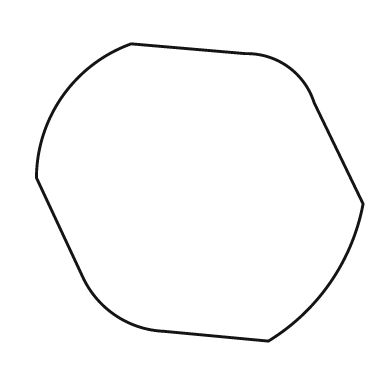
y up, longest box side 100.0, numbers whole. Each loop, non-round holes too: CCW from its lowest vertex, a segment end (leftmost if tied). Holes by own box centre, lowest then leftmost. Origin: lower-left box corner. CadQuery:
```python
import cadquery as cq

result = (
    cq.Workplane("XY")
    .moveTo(71.0, 0.0)
    .threePointArc((90.0, 18.0), (100.0, 42.0))
    .lineTo(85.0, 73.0)
    .threePointArc((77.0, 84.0), (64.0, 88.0))
    .lineTo(29.0, 91.0)
    .threePointArc((8.0, 75.0), (0.0, 50.0))
    .lineTo(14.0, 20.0)
    .threePointArc((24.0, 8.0), (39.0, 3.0))
    .close()
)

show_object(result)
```